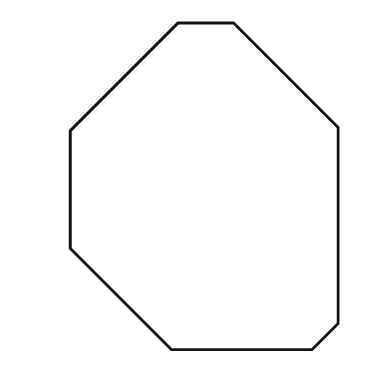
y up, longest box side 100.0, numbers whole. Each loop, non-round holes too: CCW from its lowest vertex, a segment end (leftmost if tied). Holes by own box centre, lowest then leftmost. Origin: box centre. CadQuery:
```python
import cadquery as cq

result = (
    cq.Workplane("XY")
    .moveTo(-10.0, -50.0)
    .lineTo(33.0, -50.0)
    .lineTo(41.0, -42.0)
    .lineTo(41.0, 18.0)
    .lineTo(9.0, 50.0)
    .lineTo(-8.0, 50.0)
    .lineTo(-41.0, 17.0)
    .lineTo(-41.0, -19.0)
    .close()
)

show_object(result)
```